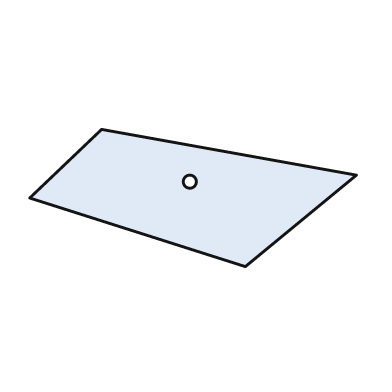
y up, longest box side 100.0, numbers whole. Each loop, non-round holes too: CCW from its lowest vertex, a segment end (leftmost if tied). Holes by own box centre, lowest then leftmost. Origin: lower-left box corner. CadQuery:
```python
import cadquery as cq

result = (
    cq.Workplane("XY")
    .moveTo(66.0, 0.0)
    .lineTo(100.0, 28.0)
    .lineTo(22.0, 42.0)
    .lineTo(0.0, 21.0)
    .close()
    .moveTo(49.0, 26.0)
    .circle(2.0)
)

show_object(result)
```